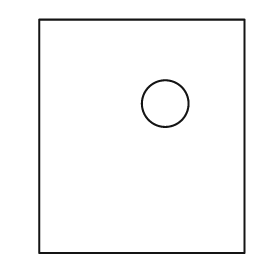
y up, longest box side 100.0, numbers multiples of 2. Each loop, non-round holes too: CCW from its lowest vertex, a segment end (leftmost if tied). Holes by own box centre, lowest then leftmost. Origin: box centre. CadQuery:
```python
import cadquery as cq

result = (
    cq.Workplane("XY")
    .moveTo(-44.0, -50.0)
    .lineTo(44.0, -50.0)
    .lineTo(44.0, 50.0)
    .lineTo(-44.0, 50.0)
    .close()
    .moveTo(10.0, 14.0)
    .circle(10.0)
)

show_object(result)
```